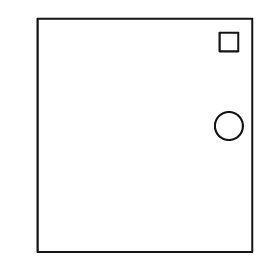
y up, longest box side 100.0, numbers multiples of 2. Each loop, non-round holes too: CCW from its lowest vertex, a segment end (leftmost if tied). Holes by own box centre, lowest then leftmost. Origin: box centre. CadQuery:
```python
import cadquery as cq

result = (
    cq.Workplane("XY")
    .moveTo(-46.0, -50.0)
    .lineTo(46.0, -50.0)
    .lineTo(46.0, 50.0)
    .lineTo(-46.0, 50.0)
    .close()
    .moveTo(36.0, 4.0)
    .circle(6.0)
    .moveTo(32.0, 36.0)
    .lineTo(40.0, 36.0)
    .lineTo(40.0, 44.0)
    .lineTo(32.0, 44.0)
    .close()
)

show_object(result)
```